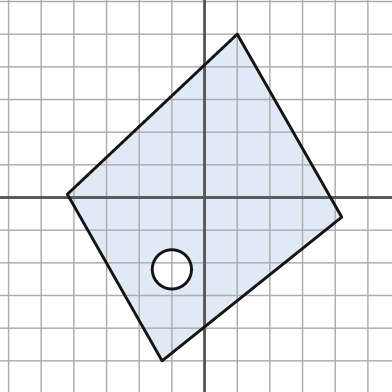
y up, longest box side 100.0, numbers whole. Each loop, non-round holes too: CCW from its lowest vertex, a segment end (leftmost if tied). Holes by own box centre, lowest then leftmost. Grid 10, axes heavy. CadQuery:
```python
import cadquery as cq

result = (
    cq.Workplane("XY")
    .moveTo(-13.0, -50.0)
    .lineTo(42.0, -6.0)
    .lineTo(10.0, 50.0)
    .lineTo(-42.0, 1.0)
    .close()
    .moveTo(-10.0, -22.0)
    .circle(6.0)
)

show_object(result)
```